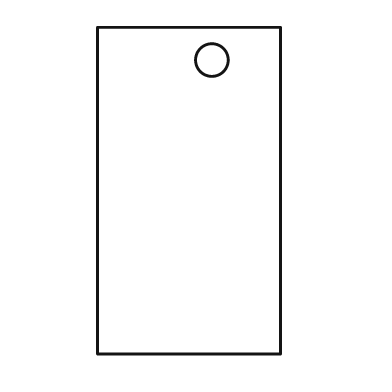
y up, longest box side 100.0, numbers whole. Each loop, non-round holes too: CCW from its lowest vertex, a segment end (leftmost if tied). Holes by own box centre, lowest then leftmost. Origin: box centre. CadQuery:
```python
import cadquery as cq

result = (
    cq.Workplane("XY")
    .moveTo(-28.0, -50.0)
    .lineTo(28.0, -50.0)
    .lineTo(28.0, 50.0)
    .lineTo(-28.0, 50.0)
    .close()
    .moveTo(7.0, 40.0)
    .circle(5.0)
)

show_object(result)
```